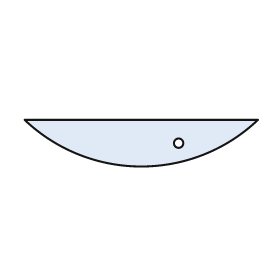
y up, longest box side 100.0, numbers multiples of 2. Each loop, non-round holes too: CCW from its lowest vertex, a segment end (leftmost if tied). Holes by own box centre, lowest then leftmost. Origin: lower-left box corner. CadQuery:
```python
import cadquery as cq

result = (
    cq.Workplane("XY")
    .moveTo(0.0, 20.0)
    .threePointArc((50.0, 0.0), (100.0, 20.0))
    .close()
    .moveTo(66.0, 10.0)
    .circle(2.0)
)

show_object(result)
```